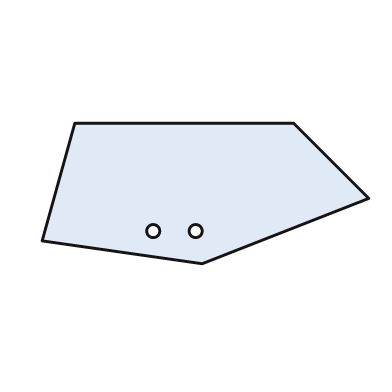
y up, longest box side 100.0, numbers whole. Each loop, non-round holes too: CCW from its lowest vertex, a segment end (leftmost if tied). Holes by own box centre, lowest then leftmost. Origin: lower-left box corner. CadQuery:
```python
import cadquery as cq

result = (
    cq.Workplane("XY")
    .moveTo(49.0, 0.0)
    .lineTo(100.0, 20.0)
    .lineTo(77.0, 43.0)
    .lineTo(10.0, 43.0)
    .lineTo(0.0, 7.0)
    .close()
    .moveTo(34.0, 10.0)
    .circle(2.0)
    .moveTo(47.0, 10.0)
    .circle(2.0)
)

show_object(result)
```